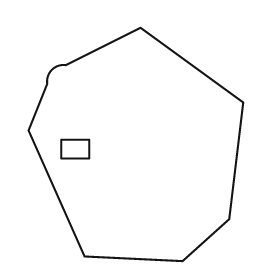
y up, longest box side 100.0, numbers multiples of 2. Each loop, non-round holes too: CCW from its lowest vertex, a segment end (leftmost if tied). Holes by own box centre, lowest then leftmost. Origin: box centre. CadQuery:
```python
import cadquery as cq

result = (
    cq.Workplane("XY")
    .moveTo(20.0, -50.0)
    .lineTo(40.0, -32.0)
    .lineTo(46.0, 18.0)
    .lineTo(2.0, 50.0)
    .lineTo(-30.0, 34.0)
    .threePointArc((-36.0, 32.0), (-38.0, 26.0))
    .lineTo(-46.0, 6.0)
    .lineTo(-22.0, -48.0)
    .close()
    .moveTo(-32.0, -6.0)
    .lineTo(-20.0, -6.0)
    .lineTo(-20.0, 2.0)
    .lineTo(-32.0, 2.0)
    .close()
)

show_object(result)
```